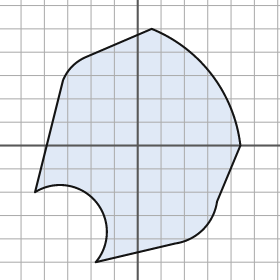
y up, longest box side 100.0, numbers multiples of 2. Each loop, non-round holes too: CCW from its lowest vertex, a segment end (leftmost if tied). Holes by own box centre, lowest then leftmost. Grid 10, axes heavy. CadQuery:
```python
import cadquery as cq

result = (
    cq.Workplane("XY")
    .moveTo(-18.0, -50.0)
    .lineTo(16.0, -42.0)
    .threePointArc((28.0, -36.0), (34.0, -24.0))
    .lineTo(44.0, 0.0)
    .threePointArc((32.0, 30.0), (6.0, 50.0))
    .lineTo(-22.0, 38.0)
    .threePointArc((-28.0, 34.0), (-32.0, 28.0))
    .lineTo(-44.0, -20.0)
    .threePointArc((-18.0, -24.0), (-18.0, -50.0))
    .close()
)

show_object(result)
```